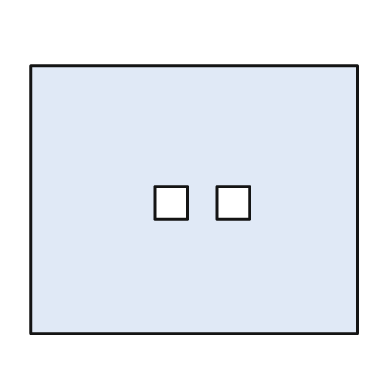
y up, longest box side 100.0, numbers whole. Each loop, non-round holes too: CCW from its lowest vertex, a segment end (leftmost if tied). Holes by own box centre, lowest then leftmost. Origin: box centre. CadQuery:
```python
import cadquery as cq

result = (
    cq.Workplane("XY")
    .moveTo(-50.0, -41.0)
    .lineTo(50.0, -41.0)
    .lineTo(50.0, 41.0)
    .lineTo(-50.0, 41.0)
    .close()
    .moveTo(-12.0, -6.0)
    .lineTo(-2.0, -6.0)
    .lineTo(-2.0, 4.0)
    .lineTo(-12.0, 4.0)
    .close()
    .moveTo(7.0, -6.0)
    .lineTo(17.0, -6.0)
    .lineTo(17.0, 4.0)
    .lineTo(7.0, 4.0)
    .close()
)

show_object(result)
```